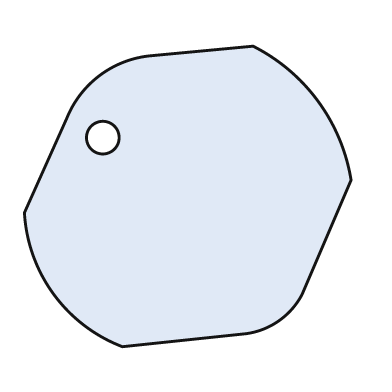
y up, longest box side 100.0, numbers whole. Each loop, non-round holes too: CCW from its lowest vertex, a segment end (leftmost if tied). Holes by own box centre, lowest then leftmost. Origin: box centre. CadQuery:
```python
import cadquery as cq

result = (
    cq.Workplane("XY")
    .moveTo(-20.0, -46.0)
    .lineTo(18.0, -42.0)
    .threePointArc((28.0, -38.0), (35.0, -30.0))
    .lineTo(50.0, 5.0)
    .threePointArc((40.0, 29.0), (20.0, 46.0))
    .lineTo(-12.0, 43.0)
    .threePointArc((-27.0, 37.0), (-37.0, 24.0))
    .lineTo(-50.0, -5.0)
    .threePointArc((-41.0, -30.0), (-20.0, -46.0))
    .close()
    .moveTo(-26.0, 18.0)
    .circle(5.0)
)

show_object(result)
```